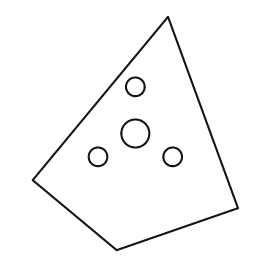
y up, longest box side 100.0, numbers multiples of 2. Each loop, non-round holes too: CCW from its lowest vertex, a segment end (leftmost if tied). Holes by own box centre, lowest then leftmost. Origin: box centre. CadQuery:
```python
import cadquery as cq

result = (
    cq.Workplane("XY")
    .moveTo(-8.0, -50.0)
    .lineTo(44.0, -32.0)
    .lineTo(14.0, 50.0)
    .lineTo(-44.0, -20.0)
    .close()
    .moveTo(-16.0, -10.0)
    .circle(4.0)
    .moveTo(16.0, -10.0)
    .circle(4.0)
    .moveTo(0.0, 0.0)
    .circle(6.0)
    .moveTo(0.0, 20.0)
    .circle(4.0)
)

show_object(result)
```